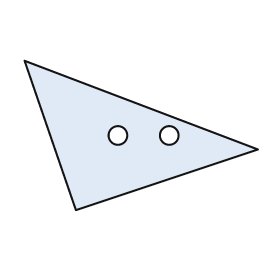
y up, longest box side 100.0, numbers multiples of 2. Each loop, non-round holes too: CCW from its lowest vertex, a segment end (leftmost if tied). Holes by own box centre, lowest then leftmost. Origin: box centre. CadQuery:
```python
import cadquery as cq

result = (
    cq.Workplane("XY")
    .moveTo(-28.0, -32.0)
    .lineTo(50.0, -6.0)
    .lineTo(-50.0, 32.0)
    .close()
    .moveTo(-10.0, 0.0)
    .circle(4.0)
    .moveTo(12.0, 0.0)
    .circle(4.0)
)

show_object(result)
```